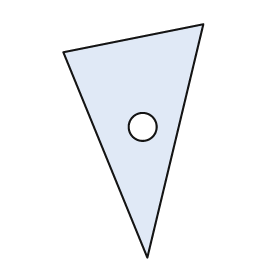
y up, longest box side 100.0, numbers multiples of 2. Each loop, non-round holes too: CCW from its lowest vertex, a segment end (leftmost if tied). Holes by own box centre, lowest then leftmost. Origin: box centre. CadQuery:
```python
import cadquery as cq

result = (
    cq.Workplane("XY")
    .moveTo(6.0, -50.0)
    .lineTo(30.0, 50.0)
    .lineTo(-30.0, 38.0)
    .close()
    .moveTo(4.0, 6.0)
    .circle(6.0)
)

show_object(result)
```